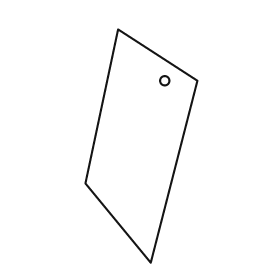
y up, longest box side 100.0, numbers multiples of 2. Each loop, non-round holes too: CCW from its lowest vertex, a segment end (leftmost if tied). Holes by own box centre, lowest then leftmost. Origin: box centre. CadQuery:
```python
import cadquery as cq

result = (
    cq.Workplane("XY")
    .moveTo(4.0, -50.0)
    .lineTo(24.0, 28.0)
    .lineTo(-10.0, 50.0)
    .lineTo(-24.0, -16.0)
    .close()
    .moveTo(10.0, 28.0)
    .circle(2.0)
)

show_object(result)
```